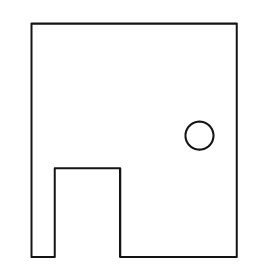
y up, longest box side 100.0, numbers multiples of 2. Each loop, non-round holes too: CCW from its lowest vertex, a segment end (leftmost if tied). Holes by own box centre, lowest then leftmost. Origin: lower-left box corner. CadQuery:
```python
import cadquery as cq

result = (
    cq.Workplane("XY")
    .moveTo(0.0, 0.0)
    .lineTo(10.0, 0.0)
    .lineTo(10.0, 38.0)
    .lineTo(38.0, 38.0)
    .lineTo(38.0, 0.0)
    .lineTo(88.0, 0.0)
    .lineTo(88.0, 100.0)
    .lineTo(0.0, 100.0)
    .close()
    .moveTo(72.0, 52.0)
    .circle(6.0)
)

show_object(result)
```